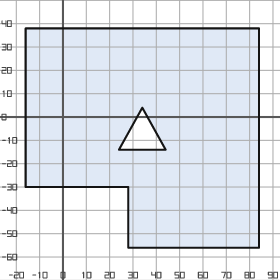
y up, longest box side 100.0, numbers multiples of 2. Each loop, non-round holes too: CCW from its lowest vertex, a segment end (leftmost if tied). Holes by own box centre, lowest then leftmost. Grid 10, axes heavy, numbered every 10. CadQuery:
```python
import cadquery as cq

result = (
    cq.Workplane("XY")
    .moveTo(28.0, -56.0)
    .lineTo(84.0, -56.0)
    .lineTo(84.0, 38.0)
    .lineTo(-16.0, 38.0)
    .lineTo(-16.0, -30.0)
    .lineTo(28.0, -30.0)
    .close()
    .moveTo(24.0, -14.0)
    .lineTo(44.0, -14.0)
    .lineTo(34.0, 4.0)
    .close()
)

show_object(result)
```